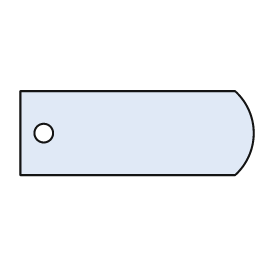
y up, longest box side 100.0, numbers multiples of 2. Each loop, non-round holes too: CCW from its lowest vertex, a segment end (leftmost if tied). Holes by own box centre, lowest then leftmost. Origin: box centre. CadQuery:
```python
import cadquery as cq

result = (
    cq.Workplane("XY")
    .moveTo(-50.0, -18.0)
    .lineTo(42.0, -18.0)
    .threePointArc((50.0, 0.0), (42.0, 18.0))
    .lineTo(-50.0, 18.0)
    .close()
    .moveTo(-40.0, 0.0)
    .circle(4.0)
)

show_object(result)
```